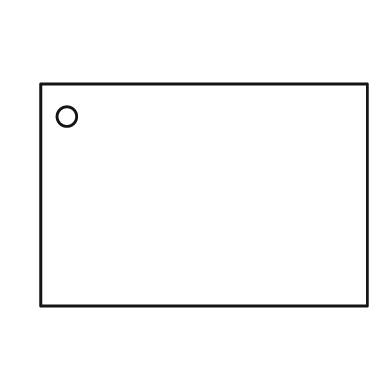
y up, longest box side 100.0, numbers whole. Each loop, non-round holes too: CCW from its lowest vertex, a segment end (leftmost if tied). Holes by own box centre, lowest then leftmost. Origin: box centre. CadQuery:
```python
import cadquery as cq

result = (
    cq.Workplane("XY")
    .moveTo(-50.0, -34.0)
    .lineTo(50.0, -34.0)
    .lineTo(50.0, 34.0)
    .lineTo(-50.0, 34.0)
    .close()
    .moveTo(-42.0, 24.0)
    .circle(3.0)
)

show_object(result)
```